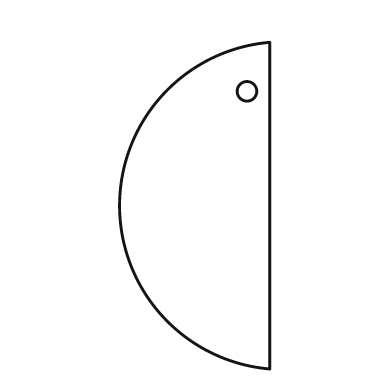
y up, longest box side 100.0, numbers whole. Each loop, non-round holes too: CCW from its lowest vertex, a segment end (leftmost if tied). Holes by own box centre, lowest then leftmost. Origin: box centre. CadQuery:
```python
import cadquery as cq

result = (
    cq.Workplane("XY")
    .moveTo(23.0, -50.0)
    .lineTo(23.0, 50.0)
    .threePointArc((-23.0, 0.0), (23.0, -50.0))
    .close()
    .moveTo(16.0, 35.0)
    .circle(3.0)
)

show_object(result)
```